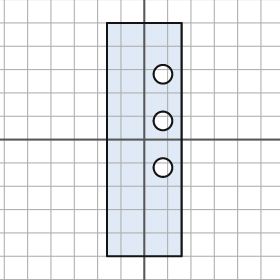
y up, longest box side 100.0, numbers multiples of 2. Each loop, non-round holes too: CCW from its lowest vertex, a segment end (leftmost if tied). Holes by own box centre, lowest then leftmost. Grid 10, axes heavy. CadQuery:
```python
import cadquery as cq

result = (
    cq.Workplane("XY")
    .moveTo(-16.0, -50.0)
    .lineTo(16.0, -50.0)
    .lineTo(16.0, 50.0)
    .lineTo(-16.0, 50.0)
    .close()
    .moveTo(8.0, -12.0)
    .circle(4.0)
    .moveTo(8.0, 8.0)
    .circle(4.0)
    .moveTo(8.0, 28.0)
    .circle(4.0)
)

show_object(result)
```